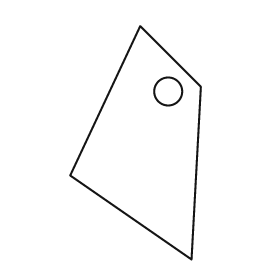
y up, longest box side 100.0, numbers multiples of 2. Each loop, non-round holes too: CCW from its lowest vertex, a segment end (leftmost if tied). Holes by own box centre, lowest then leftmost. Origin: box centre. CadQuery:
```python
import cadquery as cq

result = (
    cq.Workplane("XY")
    .moveTo(24.0, -50.0)
    .lineTo(28.0, 24.0)
    .lineTo(2.0, 50.0)
    .lineTo(-28.0, -14.0)
    .close()
    .moveTo(14.0, 22.0)
    .circle(6.0)
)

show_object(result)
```